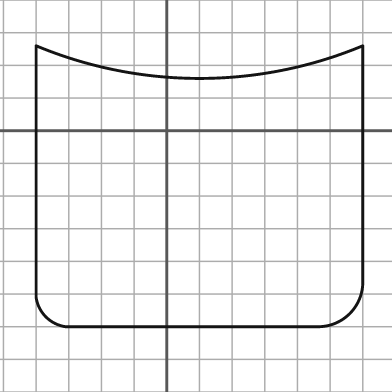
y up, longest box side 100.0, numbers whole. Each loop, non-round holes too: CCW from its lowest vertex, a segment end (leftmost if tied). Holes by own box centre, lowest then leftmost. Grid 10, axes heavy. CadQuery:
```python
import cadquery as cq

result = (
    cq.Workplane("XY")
    .moveTo(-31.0, -60.0)
    .lineTo(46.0, -60.0)
    .threePointArc((56.0, -56.0), (60.0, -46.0))
    .lineTo(60.0, 26.0)
    .threePointArc((10.0, 16.0), (-40.0, 26.0))
    .lineTo(-40.0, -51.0)
    .threePointArc((-37.0, -57.0), (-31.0, -60.0))
    .close()
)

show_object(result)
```